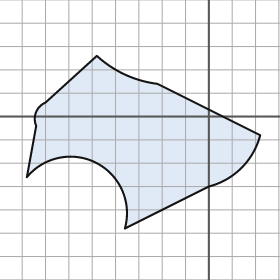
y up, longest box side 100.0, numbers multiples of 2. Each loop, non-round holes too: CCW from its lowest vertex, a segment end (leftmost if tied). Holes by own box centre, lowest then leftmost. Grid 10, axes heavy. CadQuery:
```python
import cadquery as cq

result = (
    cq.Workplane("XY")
    .moveTo(-36.0, -48.0)
    .lineTo(0.0, -30.0)
    .threePointArc((14.0, -22.0), (22.0, -8.0))
    .lineTo(-22.0, 14.0)
    .threePointArc((-36.0, 18.0), (-48.0, 26.0))
    .lineTo(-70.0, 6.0)
    .threePointArc((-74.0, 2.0), (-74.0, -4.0))
    .lineTo(-78.0, -26.0)
    .threePointArc((-48.0, -20.0), (-36.0, -48.0))
    .close()
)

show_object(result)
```